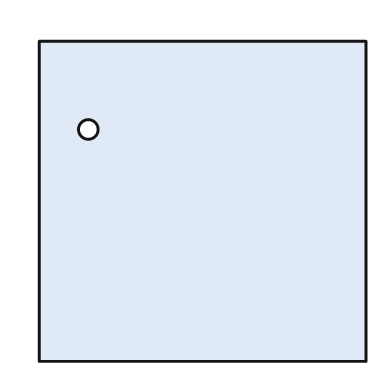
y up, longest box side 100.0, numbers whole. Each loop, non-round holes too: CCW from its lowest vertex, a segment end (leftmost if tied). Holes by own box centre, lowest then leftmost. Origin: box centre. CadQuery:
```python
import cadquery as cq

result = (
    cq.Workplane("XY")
    .moveTo(-50.0, -49.0)
    .lineTo(50.0, -49.0)
    .lineTo(50.0, 49.0)
    .lineTo(-50.0, 49.0)
    .close()
    .moveTo(-35.0, 22.0)
    .circle(3.0)
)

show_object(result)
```